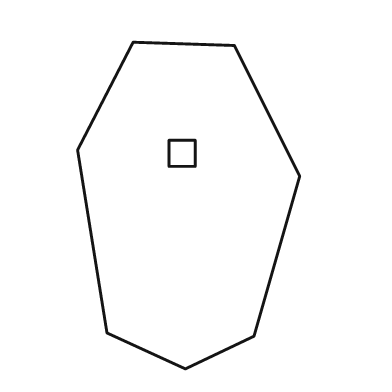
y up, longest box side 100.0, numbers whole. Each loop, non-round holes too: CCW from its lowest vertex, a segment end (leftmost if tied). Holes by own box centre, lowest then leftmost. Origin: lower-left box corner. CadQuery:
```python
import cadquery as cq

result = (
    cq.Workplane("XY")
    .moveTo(33.0, 0.0)
    .lineTo(54.0, 10.0)
    .lineTo(68.0, 59.0)
    .lineTo(48.0, 99.0)
    .lineTo(17.0, 100.0)
    .lineTo(0.0, 67.0)
    .lineTo(9.0, 11.0)
    .close()
    .moveTo(28.0, 62.0)
    .lineTo(36.0, 62.0)
    .lineTo(36.0, 70.0)
    .lineTo(28.0, 70.0)
    .close()
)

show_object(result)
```